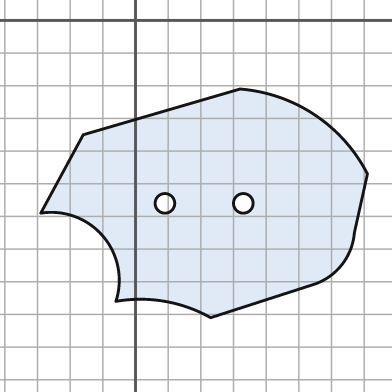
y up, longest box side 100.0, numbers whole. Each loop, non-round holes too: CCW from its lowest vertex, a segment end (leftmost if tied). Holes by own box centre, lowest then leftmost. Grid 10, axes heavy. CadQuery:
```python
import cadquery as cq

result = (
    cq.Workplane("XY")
    .moveTo(23.0, -91.0)
    .lineTo(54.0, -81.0)
    .threePointArc((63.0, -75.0), (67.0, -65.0))
    .lineTo(71.0, -47.0)
    .threePointArc((55.0, -29.0), (32.0, -21.0))
    .lineTo(-16.0, -35.0)
    .lineTo(-29.0, -59.0)
    .threePointArc((-10.0, -66.0), (-6.0, -86.0))
    .threePointArc((9.0, -86.0), (23.0, -91.0))
    .close()
    .moveTo(9.0, -56.0)
    .circle(3.0)
    .moveTo(33.0, -56.0)
    .circle(3.0)
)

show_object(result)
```